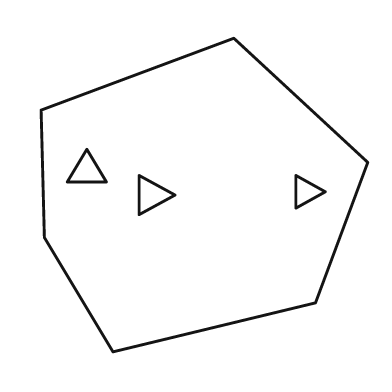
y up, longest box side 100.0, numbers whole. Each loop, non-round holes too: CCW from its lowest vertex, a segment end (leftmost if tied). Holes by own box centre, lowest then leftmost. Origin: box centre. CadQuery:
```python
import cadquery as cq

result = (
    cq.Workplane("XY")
    .moveTo(-28.0, -48.0)
    .lineTo(34.0, -33.0)
    .lineTo(50.0, 10.0)
    .lineTo(9.0, 48.0)
    .lineTo(-50.0, 26.0)
    .lineTo(-49.0, -13.0)
    .close()
    .moveTo(-20.0, -6.0)
    .lineTo(-9.0, 0.0)
    .lineTo(-20.0, 6.0)
    .close()
    .moveTo(28.0, -4.0)
    .lineTo(37.0, 1.0)
    .lineTo(28.0, 6.0)
    .close()
    .moveTo(-42.0, 4.0)
    .lineTo(-30.0, 4.0)
    .lineTo(-36.0, 14.0)
    .close()
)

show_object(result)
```